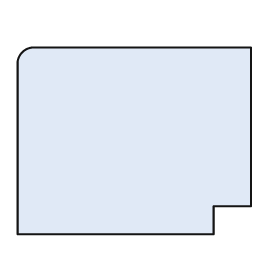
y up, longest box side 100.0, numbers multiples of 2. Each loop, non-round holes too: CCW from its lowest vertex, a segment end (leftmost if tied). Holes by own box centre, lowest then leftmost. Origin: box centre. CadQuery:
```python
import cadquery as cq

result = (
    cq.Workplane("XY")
    .moveTo(-50.0, -40.0)
    .lineTo(34.0, -40.0)
    .lineTo(34.0, -28.0)
    .lineTo(50.0, -28.0)
    .lineTo(50.0, 40.0)
    .lineTo(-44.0, 40.0)
    .threePointArc((-48.0, 38.0), (-50.0, 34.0))
    .close()
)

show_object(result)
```